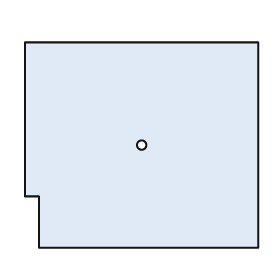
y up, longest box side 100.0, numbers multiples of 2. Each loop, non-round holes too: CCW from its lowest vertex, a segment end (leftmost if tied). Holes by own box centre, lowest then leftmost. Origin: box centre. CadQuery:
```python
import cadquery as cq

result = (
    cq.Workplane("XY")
    .moveTo(-44.0, -44.0)
    .lineTo(50.0, -44.0)
    .lineTo(50.0, 44.0)
    .lineTo(-50.0, 44.0)
    .lineTo(-50.0, -22.0)
    .lineTo(-44.0, -22.0)
    .close()
    .moveTo(0.0, 0.0)
    .circle(2.0)
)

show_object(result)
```